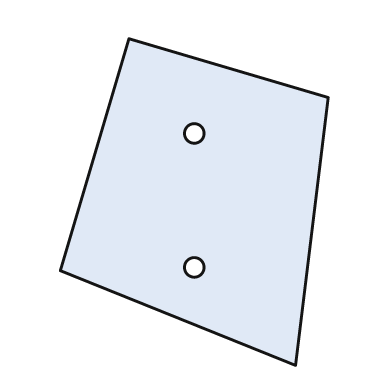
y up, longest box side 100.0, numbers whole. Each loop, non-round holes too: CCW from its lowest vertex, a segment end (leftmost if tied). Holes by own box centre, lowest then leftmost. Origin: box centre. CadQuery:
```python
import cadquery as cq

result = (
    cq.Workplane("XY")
    .moveTo(31.0, -50.0)
    .lineTo(41.0, 32.0)
    .lineTo(-20.0, 50.0)
    .lineTo(-41.0, -21.0)
    .close()
    .moveTo(0.0, -20.0)
    .circle(3.0)
    .moveTo(0.0, 21.0)
    .circle(3.0)
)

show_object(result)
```